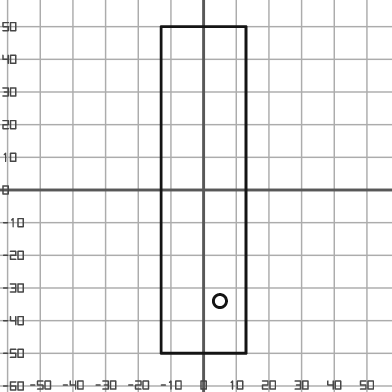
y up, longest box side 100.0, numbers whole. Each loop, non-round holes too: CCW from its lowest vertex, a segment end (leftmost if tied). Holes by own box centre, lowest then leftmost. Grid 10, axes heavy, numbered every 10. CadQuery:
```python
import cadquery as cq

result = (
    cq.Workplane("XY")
    .moveTo(-13.0, -50.0)
    .lineTo(13.0, -50.0)
    .lineTo(13.0, 50.0)
    .lineTo(-13.0, 50.0)
    .close()
    .moveTo(5.0, -34.0)
    .circle(2.0)
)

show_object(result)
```